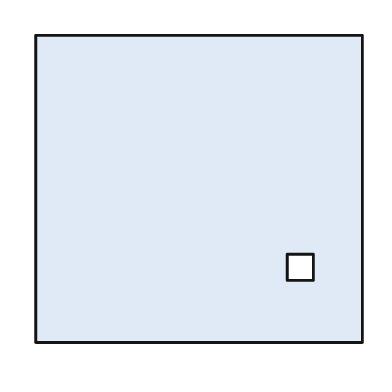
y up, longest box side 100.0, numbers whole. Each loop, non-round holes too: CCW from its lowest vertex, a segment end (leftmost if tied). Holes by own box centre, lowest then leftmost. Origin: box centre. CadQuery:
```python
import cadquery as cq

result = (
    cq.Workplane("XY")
    .moveTo(-50.0, -47.0)
    .lineTo(50.0, -47.0)
    .lineTo(50.0, 47.0)
    .lineTo(-50.0, 47.0)
    .close()
    .moveTo(27.0, -28.0)
    .lineTo(35.0, -28.0)
    .lineTo(35.0, -20.0)
    .lineTo(27.0, -20.0)
    .close()
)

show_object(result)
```